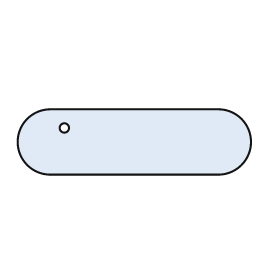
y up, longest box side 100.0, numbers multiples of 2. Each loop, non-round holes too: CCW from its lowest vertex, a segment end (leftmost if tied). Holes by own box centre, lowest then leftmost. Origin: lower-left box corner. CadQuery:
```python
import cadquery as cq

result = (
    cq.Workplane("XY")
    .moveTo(14.0, 0.0)
    .lineTo(86.0, 0.0)
    .threePointArc((100.0, 14.0), (86.0, 28.0))
    .lineTo(14.0, 28.0)
    .threePointArc((0.0, 14.0), (14.0, 0.0))
    .close()
    .moveTo(20.0, 20.0)
    .circle(2.0)
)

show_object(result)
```